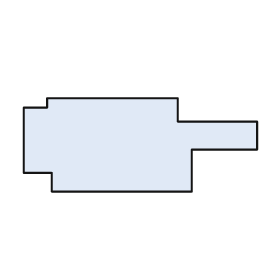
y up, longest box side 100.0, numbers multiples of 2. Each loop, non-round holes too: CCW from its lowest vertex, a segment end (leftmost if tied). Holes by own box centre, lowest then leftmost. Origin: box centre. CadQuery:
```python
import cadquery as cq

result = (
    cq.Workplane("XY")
    .moveTo(-38.0, -20.0)
    .lineTo(22.0, -20.0)
    .lineTo(22.0, -2.0)
    .lineTo(50.0, -2.0)
    .lineTo(50.0, 10.0)
    .lineTo(16.0, 10.0)
    .lineTo(16.0, 20.0)
    .lineTo(-40.0, 20.0)
    .lineTo(-40.0, 16.0)
    .lineTo(-50.0, 16.0)
    .lineTo(-50.0, -12.0)
    .lineTo(-38.0, -12.0)
    .close()
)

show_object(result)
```